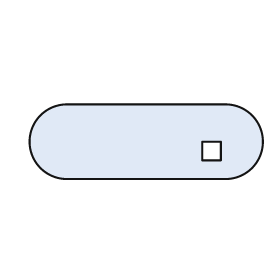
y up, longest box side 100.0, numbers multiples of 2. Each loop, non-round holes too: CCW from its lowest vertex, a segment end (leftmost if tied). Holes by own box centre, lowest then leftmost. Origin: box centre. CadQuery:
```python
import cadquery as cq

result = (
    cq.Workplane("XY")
    .moveTo(-34.0, -16.0)
    .lineTo(34.0, -16.0)
    .threePointArc((50.0, 0.0), (34.0, 16.0))
    .lineTo(-34.0, 16.0)
    .threePointArc((-50.0, 0.0), (-34.0, -16.0))
    .close()
    .moveTo(24.0, -8.0)
    .lineTo(32.0, -8.0)
    .lineTo(32.0, 0.0)
    .lineTo(24.0, 0.0)
    .close()
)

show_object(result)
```